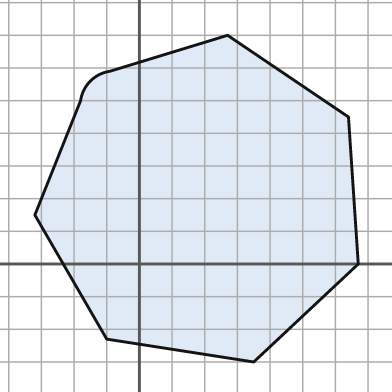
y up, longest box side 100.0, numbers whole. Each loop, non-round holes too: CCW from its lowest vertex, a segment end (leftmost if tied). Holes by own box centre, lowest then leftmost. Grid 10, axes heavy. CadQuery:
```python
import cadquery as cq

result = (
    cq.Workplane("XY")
    .moveTo(35.0, -30.0)
    .lineTo(67.0, 0.0)
    .lineTo(64.0, 45.0)
    .lineTo(27.0, 70.0)
    .lineTo(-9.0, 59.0)
    .threePointArc((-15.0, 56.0), (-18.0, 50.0))
    .lineTo(-32.0, 15.0)
    .lineTo(-10.0, -23.0)
    .close()
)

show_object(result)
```